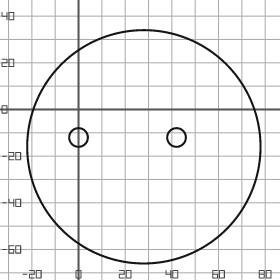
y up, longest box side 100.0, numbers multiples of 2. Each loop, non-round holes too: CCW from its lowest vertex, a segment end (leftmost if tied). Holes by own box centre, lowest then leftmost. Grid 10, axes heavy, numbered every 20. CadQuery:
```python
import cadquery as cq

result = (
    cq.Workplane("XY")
    .moveTo(28.0, -16.0)
    .circle(50.0)
    .moveTo(0.0, -12.0)
    .circle(4.0)
    .moveTo(42.0, -12.0)
    .circle(4.0)
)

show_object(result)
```